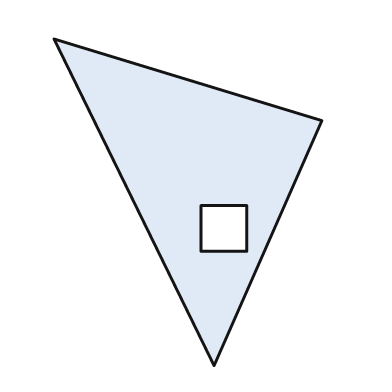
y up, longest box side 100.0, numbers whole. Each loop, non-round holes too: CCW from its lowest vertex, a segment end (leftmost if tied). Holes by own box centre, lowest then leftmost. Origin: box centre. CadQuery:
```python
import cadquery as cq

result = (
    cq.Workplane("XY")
    .moveTo(8.0, -50.0)
    .lineTo(41.0, 25.0)
    .lineTo(-41.0, 50.0)
    .close()
    .moveTo(4.0, -15.0)
    .lineTo(18.0, -15.0)
    .lineTo(18.0, -1.0)
    .lineTo(4.0, -1.0)
    .close()
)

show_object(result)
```